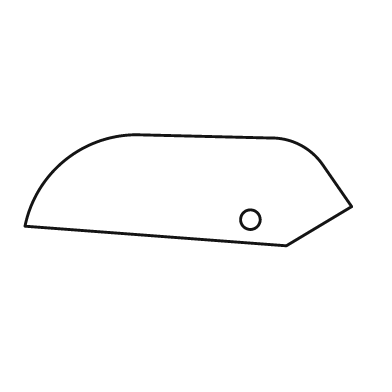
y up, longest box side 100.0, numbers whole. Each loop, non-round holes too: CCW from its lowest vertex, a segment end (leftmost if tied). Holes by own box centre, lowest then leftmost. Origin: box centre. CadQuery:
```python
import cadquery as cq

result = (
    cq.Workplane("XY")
    .moveTo(30.0, -17.0)
    .lineTo(50.0, -5.0)
    .lineTo(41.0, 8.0)
    .threePointArc((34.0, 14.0), (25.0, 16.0))
    .lineTo(-16.0, 17.0)
    .threePointArc((-38.0, 9.0), (-50.0, -11.0))
    .close()
    .moveTo(19.0, -9.0)
    .circle(3.0)
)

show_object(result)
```